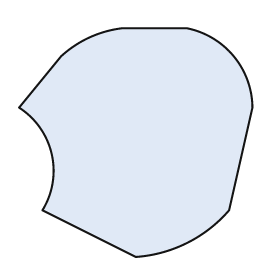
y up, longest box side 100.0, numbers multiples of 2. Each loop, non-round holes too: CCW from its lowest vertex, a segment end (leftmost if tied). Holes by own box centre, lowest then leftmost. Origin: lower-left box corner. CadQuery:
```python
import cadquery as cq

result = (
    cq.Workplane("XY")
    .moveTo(50.0, 0.0)
    .threePointArc((72.0, 6.0), (90.0, 20.0))
    .lineTo(100.0, 64.0)
    .threePointArc((92.0, 86.0), (72.0, 98.0))
    .lineTo(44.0, 98.0)
    .threePointArc((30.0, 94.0), (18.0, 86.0))
    .lineTo(0.0, 64.0)
    .threePointArc((14.0, 44.0), (10.0, 20.0))
    .close()
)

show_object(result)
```